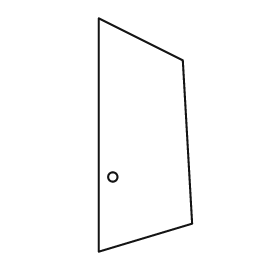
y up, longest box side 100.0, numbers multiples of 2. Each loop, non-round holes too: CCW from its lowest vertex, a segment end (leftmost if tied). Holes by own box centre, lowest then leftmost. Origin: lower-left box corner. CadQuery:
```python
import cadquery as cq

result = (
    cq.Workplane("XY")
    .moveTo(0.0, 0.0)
    .lineTo(40.0, 12.0)
    .lineTo(36.0, 82.0)
    .lineTo(0.0, 100.0)
    .close()
    .moveTo(6.0, 32.0)
    .circle(2.0)
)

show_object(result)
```